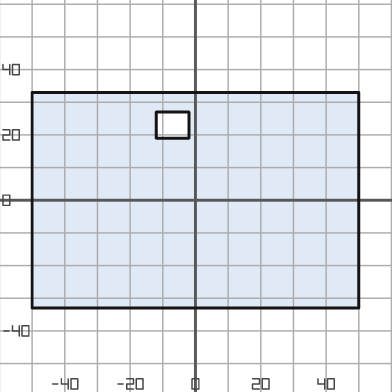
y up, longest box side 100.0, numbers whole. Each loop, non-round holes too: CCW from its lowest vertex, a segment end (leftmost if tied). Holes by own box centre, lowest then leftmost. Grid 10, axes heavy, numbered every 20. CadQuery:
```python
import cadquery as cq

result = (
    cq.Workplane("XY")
    .moveTo(-50.0, -33.0)
    .lineTo(50.0, -33.0)
    .lineTo(50.0, 33.0)
    .lineTo(-50.0, 33.0)
    .close()
    .moveTo(-12.0, 19.0)
    .lineTo(-2.0, 19.0)
    .lineTo(-2.0, 27.0)
    .lineTo(-12.0, 27.0)
    .close()
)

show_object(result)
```